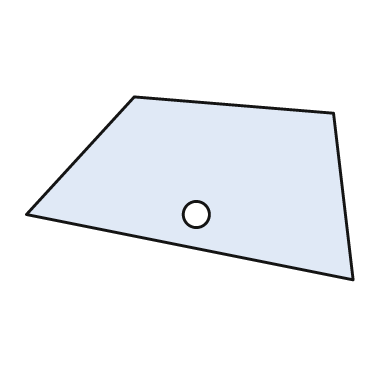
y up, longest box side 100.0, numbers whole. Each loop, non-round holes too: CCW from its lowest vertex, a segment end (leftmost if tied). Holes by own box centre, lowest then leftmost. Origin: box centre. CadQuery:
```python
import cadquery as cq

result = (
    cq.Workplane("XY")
    .moveTo(50.0, -28.0)
    .lineTo(44.0, 23.0)
    .lineTo(-17.0, 28.0)
    .lineTo(-50.0, -8.0)
    .close()
    .moveTo(2.0, -8.0)
    .circle(4.0)
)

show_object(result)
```